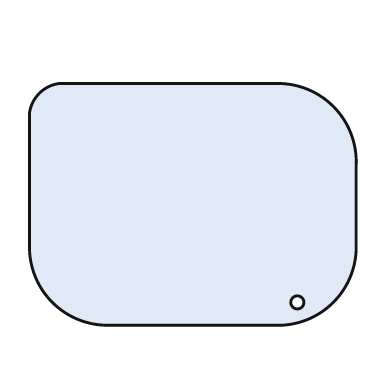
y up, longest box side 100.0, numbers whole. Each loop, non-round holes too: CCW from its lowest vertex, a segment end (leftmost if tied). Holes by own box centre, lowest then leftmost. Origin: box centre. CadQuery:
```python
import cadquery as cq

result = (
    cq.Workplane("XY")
    .moveTo(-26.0, -37.0)
    .lineTo(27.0, -37.0)
    .threePointArc((43.0, -30.0), (50.0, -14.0))
    .lineTo(50.0, 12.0)
    .threePointArc((43.0, 30.0), (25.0, 37.0))
    .lineTo(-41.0, 37.0)
    .threePointArc((-47.0, 34.0), (-50.0, 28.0))
    .lineTo(-50.0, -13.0)
    .threePointArc((-43.0, -30.0), (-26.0, -37.0))
    .close()
    .moveTo(32.0, -30.0)
    .circle(2.0)
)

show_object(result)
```